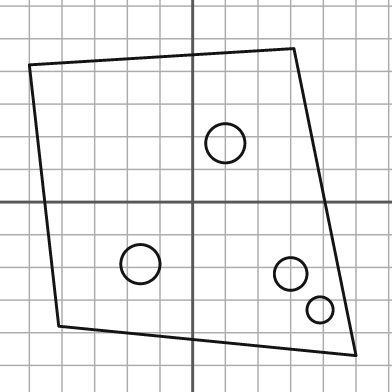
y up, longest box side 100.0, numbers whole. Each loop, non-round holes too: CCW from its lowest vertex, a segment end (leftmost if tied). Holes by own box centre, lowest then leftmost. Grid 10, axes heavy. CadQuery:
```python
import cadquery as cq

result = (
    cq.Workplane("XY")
    .moveTo(50.0, -47.0)
    .lineTo(31.0, 47.0)
    .lineTo(-50.0, 42.0)
    .lineTo(-41.0, -38.0)
    .close()
    .moveTo(39.0, -33.0)
    .circle(4.0)
    .moveTo(30.0, -22.0)
    .circle(5.0)
    .moveTo(-16.0, -19.0)
    .circle(6.0)
    .moveTo(10.0, 18.0)
    .circle(6.0)
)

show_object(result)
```